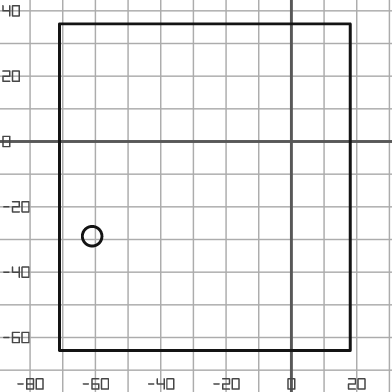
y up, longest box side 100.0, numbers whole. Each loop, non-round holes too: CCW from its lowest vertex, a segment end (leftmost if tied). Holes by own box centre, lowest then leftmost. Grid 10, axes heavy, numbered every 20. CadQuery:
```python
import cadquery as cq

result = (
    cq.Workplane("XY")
    .moveTo(-71.0, -64.0)
    .lineTo(18.0, -64.0)
    .lineTo(18.0, 36.0)
    .lineTo(-71.0, 36.0)
    .close()
    .moveTo(-61.0, -29.0)
    .circle(3.0)
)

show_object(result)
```